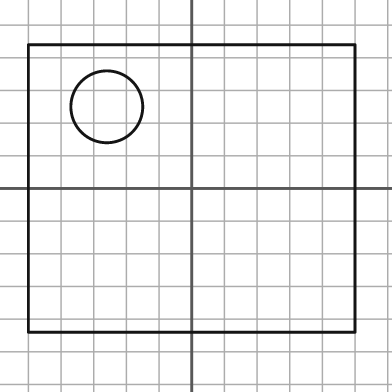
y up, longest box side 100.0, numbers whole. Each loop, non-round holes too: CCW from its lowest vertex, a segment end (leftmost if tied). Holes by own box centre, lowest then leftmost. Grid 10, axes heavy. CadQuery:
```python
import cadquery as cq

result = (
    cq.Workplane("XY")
    .moveTo(-50.0, -44.0)
    .lineTo(50.0, -44.0)
    .lineTo(50.0, 44.0)
    .lineTo(-50.0, 44.0)
    .close()
    .moveTo(-26.0, 25.0)
    .circle(11.0)
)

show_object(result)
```